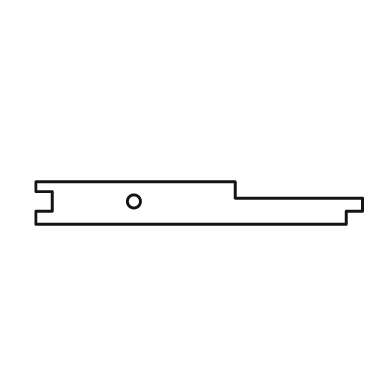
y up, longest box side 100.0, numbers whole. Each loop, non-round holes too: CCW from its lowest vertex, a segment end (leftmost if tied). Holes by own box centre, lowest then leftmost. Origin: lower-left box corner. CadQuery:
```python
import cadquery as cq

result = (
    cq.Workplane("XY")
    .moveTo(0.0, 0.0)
    .lineTo(95.0, 0.0)
    .lineTo(95.0, 4.0)
    .lineTo(100.0, 4.0)
    .lineTo(100.0, 8.0)
    .lineTo(61.0, 8.0)
    .lineTo(61.0, 13.0)
    .lineTo(0.0, 13.0)
    .lineTo(0.0, 10.0)
    .lineTo(5.0, 10.0)
    .lineTo(5.0, 4.0)
    .lineTo(0.0, 4.0)
    .close()
    .moveTo(30.0, 7.0)
    .circle(2.0)
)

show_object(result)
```